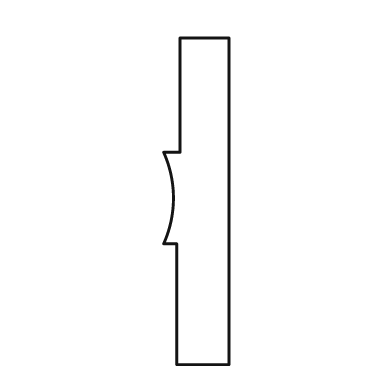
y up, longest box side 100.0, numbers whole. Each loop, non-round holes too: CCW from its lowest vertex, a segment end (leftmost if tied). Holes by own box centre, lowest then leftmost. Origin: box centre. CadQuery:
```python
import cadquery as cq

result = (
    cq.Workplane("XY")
    .moveTo(-6.0, -50.0)
    .lineTo(10.0, -50.0)
    .lineTo(10.0, 50.0)
    .lineTo(-5.0, 50.0)
    .lineTo(-5.0, 15.0)
    .lineTo(-10.0, 15.0)
    .threePointArc((-7.0, 1.0), (-10.0, -13.0))
    .lineTo(-6.0, -13.0)
    .close()
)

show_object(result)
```